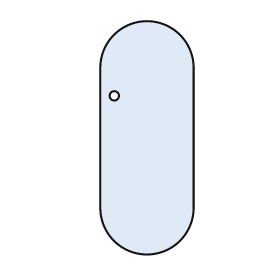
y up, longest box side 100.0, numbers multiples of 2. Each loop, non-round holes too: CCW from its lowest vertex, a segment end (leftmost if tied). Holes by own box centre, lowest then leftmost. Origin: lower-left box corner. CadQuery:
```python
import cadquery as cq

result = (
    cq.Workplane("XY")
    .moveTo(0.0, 20.0)
    .threePointArc((20.0, 0.0), (40.0, 20.0))
    .lineTo(40.0, 80.0)
    .threePointArc((20.0, 100.0), (0.0, 80.0))
    .close()
    .moveTo(6.0, 68.0)
    .circle(2.0)
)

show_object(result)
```